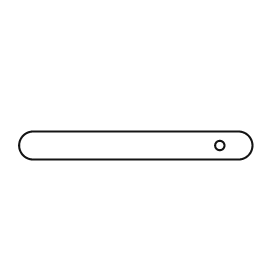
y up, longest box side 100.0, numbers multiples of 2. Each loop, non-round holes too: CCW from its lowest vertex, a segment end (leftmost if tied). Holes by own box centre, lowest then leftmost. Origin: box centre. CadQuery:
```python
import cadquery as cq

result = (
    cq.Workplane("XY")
    .moveTo(-44.0, -6.0)
    .lineTo(44.0, -6.0)
    .threePointArc((50.0, 0.0), (44.0, 6.0))
    .lineTo(-44.0, 6.0)
    .threePointArc((-50.0, 0.0), (-44.0, -6.0))
    .close()
    .moveTo(36.0, 0.0)
    .circle(2.0)
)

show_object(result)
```